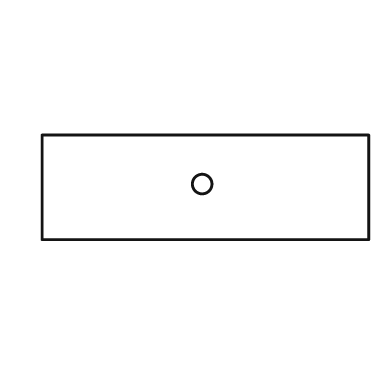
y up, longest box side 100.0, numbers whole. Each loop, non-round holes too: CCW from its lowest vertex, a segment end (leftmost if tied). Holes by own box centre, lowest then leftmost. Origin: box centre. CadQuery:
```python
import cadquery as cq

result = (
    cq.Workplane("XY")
    .moveTo(-50.0, -16.0)
    .lineTo(50.0, -16.0)
    .lineTo(50.0, 16.0)
    .lineTo(-50.0, 16.0)
    .close()
    .moveTo(-1.0, 1.0)
    .circle(3.0)
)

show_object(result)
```